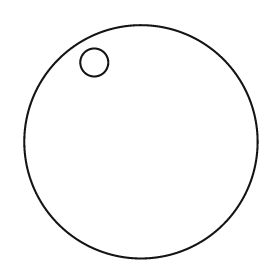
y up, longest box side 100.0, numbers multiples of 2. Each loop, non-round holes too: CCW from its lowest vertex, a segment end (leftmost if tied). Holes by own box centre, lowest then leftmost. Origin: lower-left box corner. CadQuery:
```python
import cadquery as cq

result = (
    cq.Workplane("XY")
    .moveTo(50.0, 50.0)
    .circle(50.0)
    .moveTo(30.0, 84.0)
    .circle(6.0)
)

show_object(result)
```